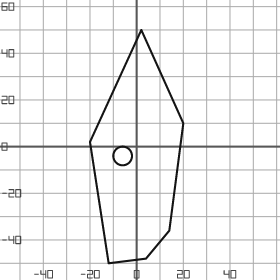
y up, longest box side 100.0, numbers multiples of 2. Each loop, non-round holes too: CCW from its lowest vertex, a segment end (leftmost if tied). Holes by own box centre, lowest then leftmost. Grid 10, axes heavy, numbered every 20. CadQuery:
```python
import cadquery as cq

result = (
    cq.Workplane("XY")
    .moveTo(-12.0, -50.0)
    .lineTo(4.0, -48.0)
    .lineTo(14.0, -36.0)
    .lineTo(20.0, 10.0)
    .lineTo(2.0, 50.0)
    .lineTo(-20.0, 2.0)
    .close()
    .moveTo(-6.0, -4.0)
    .circle(4.0)
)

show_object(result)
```